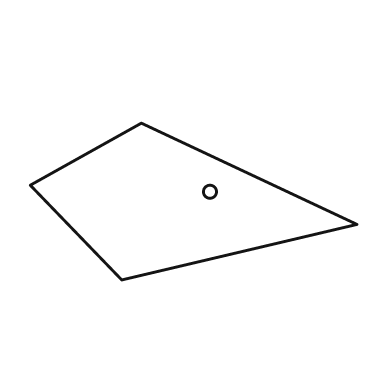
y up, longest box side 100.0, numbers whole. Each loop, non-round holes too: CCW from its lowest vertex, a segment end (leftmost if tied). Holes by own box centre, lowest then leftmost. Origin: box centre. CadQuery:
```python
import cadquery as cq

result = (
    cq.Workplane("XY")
    .moveTo(-22.0, -24.0)
    .lineTo(50.0, -7.0)
    .lineTo(-16.0, 24.0)
    .lineTo(-50.0, 5.0)
    .close()
    .moveTo(5.0, 3.0)
    .circle(2.0)
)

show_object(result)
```